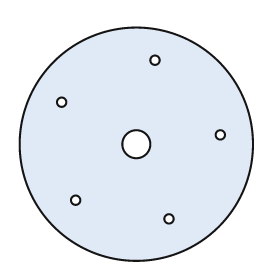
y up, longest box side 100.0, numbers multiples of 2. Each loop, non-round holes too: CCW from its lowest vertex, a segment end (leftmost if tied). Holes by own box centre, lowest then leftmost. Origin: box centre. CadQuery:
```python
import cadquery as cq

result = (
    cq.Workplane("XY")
    .moveTo(0.0, 0.0)
    .circle(50.0)
    .moveTo(14.0, -32.0)
    .circle(2.0)
    .moveTo(-26.0, -24.0)
    .circle(2.0)
    .moveTo(0.0, 0.0)
    .circle(6.0)
    .moveTo(36.0, 4.0)
    .circle(2.0)
    .moveTo(-32.0, 18.0)
    .circle(2.0)
    .moveTo(8.0, 36.0)
    .circle(2.0)
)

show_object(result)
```